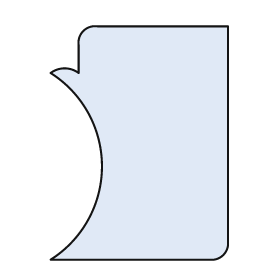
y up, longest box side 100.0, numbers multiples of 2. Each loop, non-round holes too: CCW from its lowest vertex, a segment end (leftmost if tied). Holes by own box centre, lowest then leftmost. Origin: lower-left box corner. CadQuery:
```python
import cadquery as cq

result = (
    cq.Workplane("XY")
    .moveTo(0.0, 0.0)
    .lineTo(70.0, 0.0)
    .threePointArc((74.0, 2.0), (76.0, 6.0))
    .lineTo(76.0, 100.0)
    .lineTo(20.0, 100.0)
    .threePointArc((14.0, 98.0), (12.0, 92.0))
    .lineTo(12.0, 80.0)
    .threePointArc((6.0, 82.0), (0.0, 80.0))
    .threePointArc((22.0, 40.0), (0.0, 0.0))
    .close()
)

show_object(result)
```